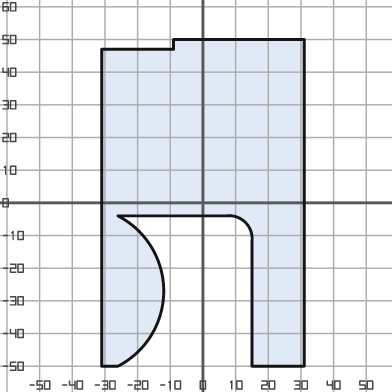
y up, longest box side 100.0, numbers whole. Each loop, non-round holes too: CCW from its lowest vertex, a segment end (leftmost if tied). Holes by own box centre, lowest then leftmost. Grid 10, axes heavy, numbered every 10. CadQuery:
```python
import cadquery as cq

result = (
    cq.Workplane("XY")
    .moveTo(-31.0, -50.0)
    .lineTo(-26.0, -50.0)
    .threePointArc((-12.0, -27.0), (-26.0, -4.0))
    .lineTo(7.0, -4.0)
    .threePointArc((13.0, -6.0), (15.0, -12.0))
    .lineTo(15.0, -50.0)
    .lineTo(31.0, -50.0)
    .lineTo(31.0, 50.0)
    .lineTo(-9.0, 50.0)
    .lineTo(-9.0, 47.0)
    .lineTo(-31.0, 47.0)
    .close()
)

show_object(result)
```